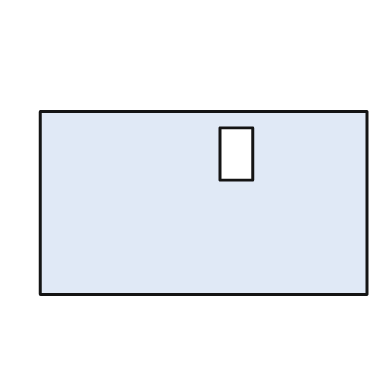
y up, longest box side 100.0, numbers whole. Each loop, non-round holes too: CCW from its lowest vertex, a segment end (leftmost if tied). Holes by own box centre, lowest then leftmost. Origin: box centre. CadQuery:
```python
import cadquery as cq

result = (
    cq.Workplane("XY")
    .moveTo(-50.0, -28.0)
    .lineTo(50.0, -28.0)
    .lineTo(50.0, 28.0)
    .lineTo(-50.0, 28.0)
    .close()
    .moveTo(5.0, 7.0)
    .lineTo(15.0, 7.0)
    .lineTo(15.0, 23.0)
    .lineTo(5.0, 23.0)
    .close()
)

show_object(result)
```